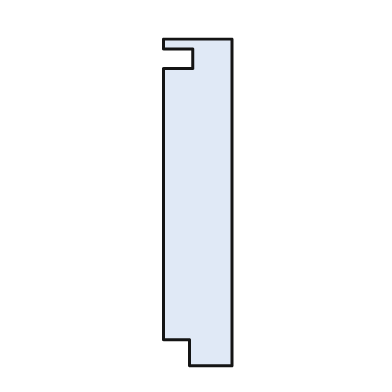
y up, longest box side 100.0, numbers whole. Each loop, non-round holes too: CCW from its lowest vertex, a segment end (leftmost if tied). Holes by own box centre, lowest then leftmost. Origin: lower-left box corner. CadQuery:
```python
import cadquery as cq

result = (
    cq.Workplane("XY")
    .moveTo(8.0, 0.0)
    .lineTo(21.0, 0.0)
    .lineTo(21.0, 100.0)
    .lineTo(0.0, 100.0)
    .lineTo(0.0, 97.0)
    .lineTo(9.0, 97.0)
    .lineTo(9.0, 91.0)
    .lineTo(0.0, 91.0)
    .lineTo(0.0, 8.0)
    .lineTo(8.0, 8.0)
    .close()
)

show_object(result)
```